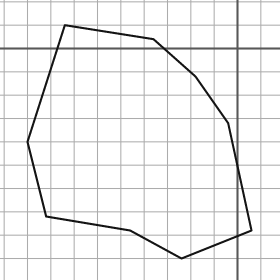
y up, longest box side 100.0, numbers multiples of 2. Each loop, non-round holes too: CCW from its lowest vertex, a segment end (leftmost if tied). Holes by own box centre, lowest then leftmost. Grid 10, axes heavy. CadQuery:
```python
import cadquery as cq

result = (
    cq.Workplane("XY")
    .moveTo(-24.0, -90.0)
    .lineTo(6.0, -78.0)
    .lineTo(-4.0, -32.0)
    .lineTo(-18.0, -12.0)
    .lineTo(-36.0, 4.0)
    .lineTo(-74.0, 10.0)
    .lineTo(-90.0, -40.0)
    .lineTo(-82.0, -72.0)
    .lineTo(-46.0, -78.0)
    .close()
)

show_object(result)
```